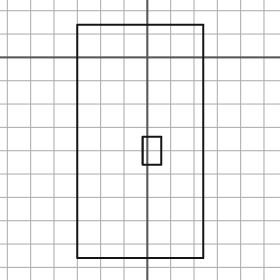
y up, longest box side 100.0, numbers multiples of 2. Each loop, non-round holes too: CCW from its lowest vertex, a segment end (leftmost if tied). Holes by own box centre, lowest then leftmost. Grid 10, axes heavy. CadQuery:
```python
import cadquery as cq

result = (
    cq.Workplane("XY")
    .moveTo(-30.0, -86.0)
    .lineTo(24.0, -86.0)
    .lineTo(24.0, 14.0)
    .lineTo(-30.0, 14.0)
    .close()
    .moveTo(-2.0, -46.0)
    .lineTo(6.0, -46.0)
    .lineTo(6.0, -34.0)
    .lineTo(-2.0, -34.0)
    .close()
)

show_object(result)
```